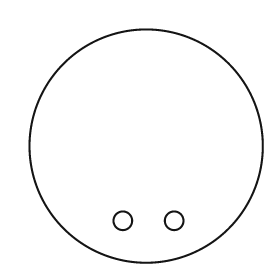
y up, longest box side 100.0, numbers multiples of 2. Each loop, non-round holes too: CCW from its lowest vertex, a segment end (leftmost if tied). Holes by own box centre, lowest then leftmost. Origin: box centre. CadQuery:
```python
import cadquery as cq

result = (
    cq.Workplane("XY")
    .moveTo(0.0, 0.0)
    .circle(50.0)
    .moveTo(-10.0, -32.0)
    .circle(4.0)
    .moveTo(12.0, -32.0)
    .circle(4.0)
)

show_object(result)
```